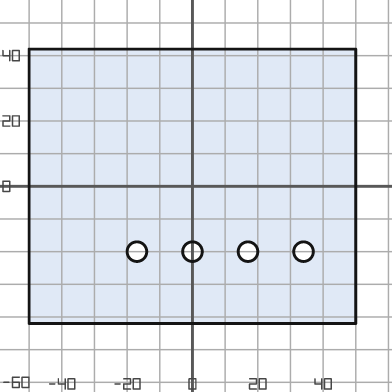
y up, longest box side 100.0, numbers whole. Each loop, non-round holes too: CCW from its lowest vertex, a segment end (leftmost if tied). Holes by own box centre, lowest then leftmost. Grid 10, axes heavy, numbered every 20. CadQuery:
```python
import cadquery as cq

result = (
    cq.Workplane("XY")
    .moveTo(-50.0, -42.0)
    .lineTo(50.0, -42.0)
    .lineTo(50.0, 42.0)
    .lineTo(-50.0, 42.0)
    .close()
    .moveTo(-17.0, -20.0)
    .circle(3.0)
    .moveTo(0.0, -20.0)
    .circle(3.0)
    .moveTo(17.0, -20.0)
    .circle(3.0)
    .moveTo(34.0, -20.0)
    .circle(3.0)
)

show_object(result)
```